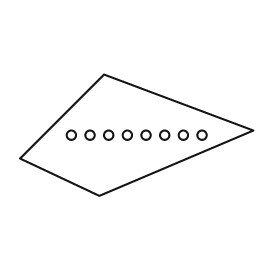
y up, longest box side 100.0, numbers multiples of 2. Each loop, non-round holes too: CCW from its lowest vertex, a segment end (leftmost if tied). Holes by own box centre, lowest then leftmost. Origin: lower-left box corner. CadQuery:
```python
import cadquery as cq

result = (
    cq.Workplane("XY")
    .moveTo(34.0, 0.0)
    .lineTo(100.0, 28.0)
    .lineTo(36.0, 52.0)
    .lineTo(0.0, 16.0)
    .close()
    .moveTo(22.0, 26.0)
    .circle(2.0)
    .moveTo(30.0, 26.0)
    .circle(2.0)
    .moveTo(38.0, 26.0)
    .circle(2.0)
    .moveTo(46.0, 26.0)
    .circle(2.0)
    .moveTo(54.0, 26.0)
    .circle(2.0)
    .moveTo(62.0, 26.0)
    .circle(2.0)
    .moveTo(70.0, 26.0)
    .circle(2.0)
    .moveTo(78.0, 26.0)
    .circle(2.0)
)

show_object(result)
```